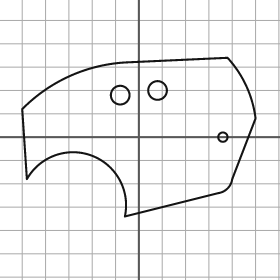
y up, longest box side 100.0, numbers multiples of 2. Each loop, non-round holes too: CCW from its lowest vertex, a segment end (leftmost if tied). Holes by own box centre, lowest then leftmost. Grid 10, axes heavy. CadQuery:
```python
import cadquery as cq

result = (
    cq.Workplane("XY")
    .moveTo(-6.0, -34.0)
    .lineTo(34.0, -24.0)
    .threePointArc((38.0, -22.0), (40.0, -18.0))
    .lineTo(50.0, 8.0)
    .threePointArc((46.0, 22.0), (38.0, 34.0))
    .lineTo(-6.0, 32.0)
    .threePointArc((-30.0, 26.0), (-50.0, 12.0))
    .lineTo(-48.0, -18.0)
    .threePointArc((-20.0, -8.0), (-6.0, -34.0))
    .close()
    .moveTo(36.0, 0.0)
    .circle(2.0)
    .moveTo(-8.0, 18.0)
    .circle(4.0)
    .moveTo(8.0, 20.0)
    .circle(4.0)
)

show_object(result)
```